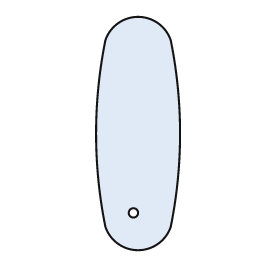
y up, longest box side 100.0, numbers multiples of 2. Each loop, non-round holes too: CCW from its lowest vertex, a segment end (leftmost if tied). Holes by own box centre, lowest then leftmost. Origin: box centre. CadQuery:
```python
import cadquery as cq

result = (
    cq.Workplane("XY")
    .moveTo(-14.0, -40.0)
    .threePointArc((0.0, -50.0), (14.0, -40.0))
    .threePointArc((18.0, 0.0), (14.0, 40.0))
    .threePointArc((0.0, 50.0), (-14.0, 40.0))
    .threePointArc((-18.0, 0.0), (-14.0, -40.0))
    .close()
    .moveTo(-2.0, -34.0)
    .circle(2.0)
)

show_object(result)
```